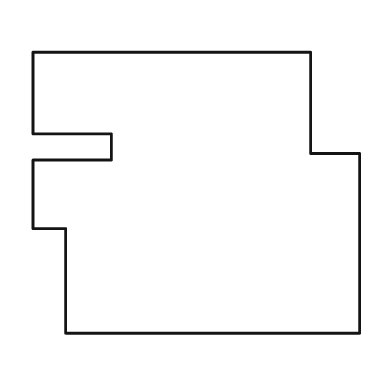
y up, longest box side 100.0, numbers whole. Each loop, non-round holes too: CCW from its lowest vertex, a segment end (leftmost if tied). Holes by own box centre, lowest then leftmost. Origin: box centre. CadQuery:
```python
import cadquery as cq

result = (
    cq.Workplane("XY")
    .moveTo(-40.0, -43.0)
    .lineTo(50.0, -43.0)
    .lineTo(50.0, 12.0)
    .lineTo(35.0, 12.0)
    .lineTo(35.0, 43.0)
    .lineTo(-50.0, 43.0)
    .lineTo(-50.0, 18.0)
    .lineTo(-26.0, 18.0)
    .lineTo(-26.0, 10.0)
    .lineTo(-50.0, 10.0)
    .lineTo(-50.0, -11.0)
    .lineTo(-40.0, -11.0)
    .close()
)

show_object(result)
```